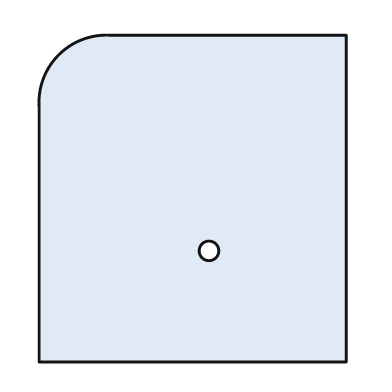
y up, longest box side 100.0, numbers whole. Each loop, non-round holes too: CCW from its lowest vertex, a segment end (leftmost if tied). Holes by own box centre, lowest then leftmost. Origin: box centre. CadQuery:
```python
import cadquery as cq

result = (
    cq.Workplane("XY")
    .moveTo(-47.0, -50.0)
    .lineTo(47.0, -50.0)
    .lineTo(47.0, 50.0)
    .lineTo(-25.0, 50.0)
    .threePointArc((-41.0, 44.0), (-47.0, 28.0))
    .close()
    .moveTo(5.0, -16.0)
    .circle(3.0)
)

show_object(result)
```